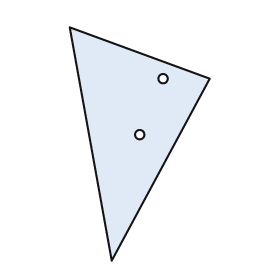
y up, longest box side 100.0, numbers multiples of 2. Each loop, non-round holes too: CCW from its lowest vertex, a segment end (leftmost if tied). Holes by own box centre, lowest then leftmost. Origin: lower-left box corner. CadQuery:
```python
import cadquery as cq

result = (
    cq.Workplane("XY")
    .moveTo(18.0, 0.0)
    .lineTo(60.0, 78.0)
    .lineTo(0.0, 100.0)
    .close()
    .moveTo(30.0, 54.0)
    .circle(2.0)
    .moveTo(40.0, 78.0)
    .circle(2.0)
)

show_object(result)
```